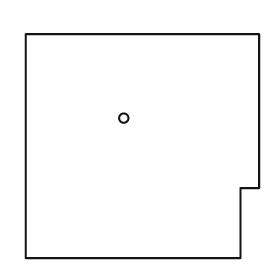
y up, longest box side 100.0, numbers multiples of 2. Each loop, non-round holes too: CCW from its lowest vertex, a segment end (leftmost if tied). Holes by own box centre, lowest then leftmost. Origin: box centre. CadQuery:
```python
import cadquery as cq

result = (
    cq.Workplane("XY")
    .moveTo(-50.0, -48.0)
    .lineTo(42.0, -48.0)
    .lineTo(42.0, -18.0)
    .lineTo(50.0, -18.0)
    .lineTo(50.0, 48.0)
    .lineTo(-50.0, 48.0)
    .close()
    .moveTo(-8.0, 12.0)
    .circle(2.0)
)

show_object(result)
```